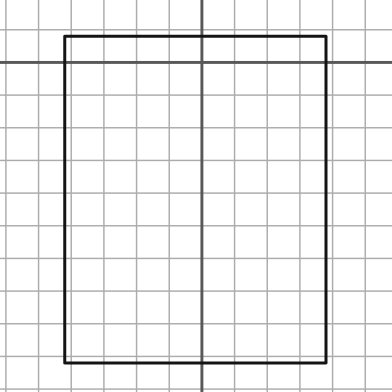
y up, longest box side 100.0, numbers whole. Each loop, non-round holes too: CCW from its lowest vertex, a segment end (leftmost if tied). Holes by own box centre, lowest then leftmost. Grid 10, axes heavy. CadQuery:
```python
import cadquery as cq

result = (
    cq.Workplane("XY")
    .moveTo(-42.0, -92.0)
    .lineTo(38.0, -92.0)
    .lineTo(38.0, 8.0)
    .lineTo(-42.0, 8.0)
    .close()
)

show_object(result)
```